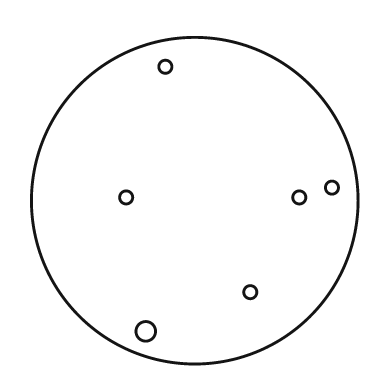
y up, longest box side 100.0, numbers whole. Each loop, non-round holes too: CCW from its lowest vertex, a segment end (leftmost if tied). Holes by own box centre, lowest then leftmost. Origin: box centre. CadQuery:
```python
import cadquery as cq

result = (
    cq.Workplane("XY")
    .moveTo(0.0, 0.0)
    .circle(50.0)
    .moveTo(-15.0, -40.0)
    .circle(3.0)
    .moveTo(17.0, -28.0)
    .circle(2.0)
    .moveTo(-21.0, 1.0)
    .circle(2.0)
    .moveTo(32.0, 1.0)
    .circle(2.0)
    .moveTo(42.0, 4.0)
    .circle(2.0)
    .moveTo(-9.0, 41.0)
    .circle(2.0)
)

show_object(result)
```